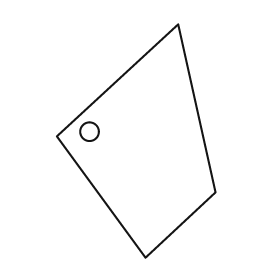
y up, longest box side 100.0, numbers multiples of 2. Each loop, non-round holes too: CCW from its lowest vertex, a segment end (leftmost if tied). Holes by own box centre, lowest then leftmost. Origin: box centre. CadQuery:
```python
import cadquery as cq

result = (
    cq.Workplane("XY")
    .moveTo(4.0, -50.0)
    .lineTo(34.0, -22.0)
    .lineTo(18.0, 50.0)
    .lineTo(-34.0, 2.0)
    .close()
    .moveTo(-20.0, 4.0)
    .circle(4.0)
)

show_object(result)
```